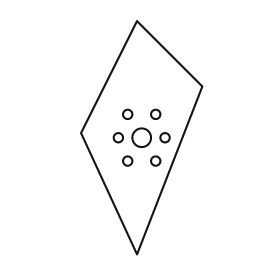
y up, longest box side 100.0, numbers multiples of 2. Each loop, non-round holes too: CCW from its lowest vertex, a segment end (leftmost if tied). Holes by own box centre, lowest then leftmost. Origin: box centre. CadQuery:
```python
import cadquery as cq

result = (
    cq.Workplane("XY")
    .moveTo(-2.0, -50.0)
    .lineTo(26.0, 22.0)
    .lineTo(-2.0, 50.0)
    .lineTo(-26.0, 2.0)
    .close()
    .moveTo(-6.0, -10.0)
    .circle(2.0)
    .moveTo(6.0, -10.0)
    .circle(2.0)
    .moveTo(-10.0, 0.0)
    .circle(2.0)
    .moveTo(0.0, 0.0)
    .circle(4.0)
    .moveTo(10.0, 0.0)
    .circle(2.0)
    .moveTo(-6.0, 10.0)
    .circle(2.0)
    .moveTo(6.0, 10.0)
    .circle(2.0)
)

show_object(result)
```